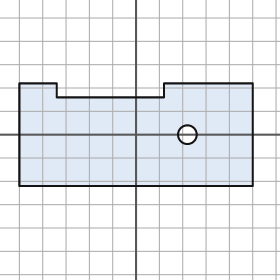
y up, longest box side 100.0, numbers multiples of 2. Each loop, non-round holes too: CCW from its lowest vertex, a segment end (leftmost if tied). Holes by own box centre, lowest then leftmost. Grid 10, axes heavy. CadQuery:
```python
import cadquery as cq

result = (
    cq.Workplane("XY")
    .moveTo(-50.0, -22.0)
    .lineTo(50.0, -22.0)
    .lineTo(50.0, 22.0)
    .lineTo(12.0, 22.0)
    .lineTo(12.0, 16.0)
    .lineTo(-34.0, 16.0)
    .lineTo(-34.0, 22.0)
    .lineTo(-50.0, 22.0)
    .close()
    .moveTo(22.0, 0.0)
    .circle(4.0)
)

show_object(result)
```